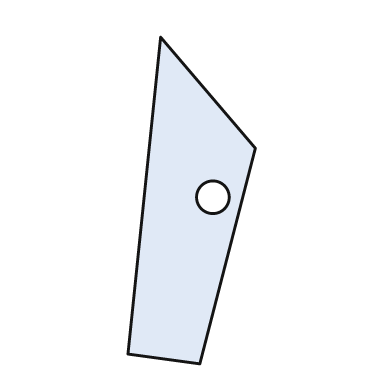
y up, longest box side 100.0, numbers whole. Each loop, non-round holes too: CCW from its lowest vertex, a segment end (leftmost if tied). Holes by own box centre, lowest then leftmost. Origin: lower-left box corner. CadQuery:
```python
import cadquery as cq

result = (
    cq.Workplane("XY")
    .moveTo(22.0, 0.0)
    .lineTo(39.0, 66.0)
    .lineTo(10.0, 100.0)
    .lineTo(0.0, 3.0)
    .close()
    .moveTo(26.0, 51.0)
    .circle(5.0)
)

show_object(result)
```